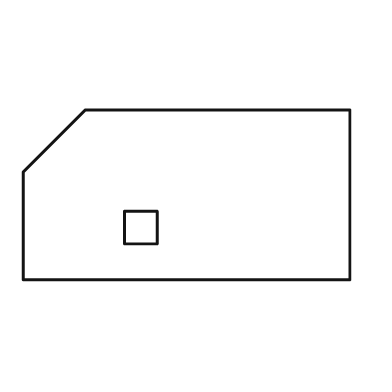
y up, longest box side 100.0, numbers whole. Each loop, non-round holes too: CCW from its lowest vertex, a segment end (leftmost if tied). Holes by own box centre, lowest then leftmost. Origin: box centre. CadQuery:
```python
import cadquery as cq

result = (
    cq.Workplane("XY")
    .moveTo(-50.0, -26.0)
    .lineTo(50.0, -26.0)
    .lineTo(50.0, 26.0)
    .lineTo(-31.0, 26.0)
    .lineTo(-50.0, 7.0)
    .close()
    .moveTo(-19.0, -15.0)
    .lineTo(-9.0, -15.0)
    .lineTo(-9.0, -5.0)
    .lineTo(-19.0, -5.0)
    .close()
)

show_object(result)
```